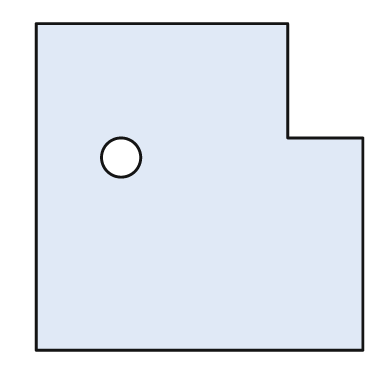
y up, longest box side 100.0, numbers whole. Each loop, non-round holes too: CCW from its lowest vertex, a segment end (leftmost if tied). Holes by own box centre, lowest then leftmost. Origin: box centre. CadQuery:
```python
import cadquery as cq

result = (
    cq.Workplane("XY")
    .moveTo(-50.0, -50.0)
    .lineTo(50.0, -50.0)
    .lineTo(50.0, 15.0)
    .lineTo(27.0, 15.0)
    .lineTo(27.0, 50.0)
    .lineTo(-50.0, 50.0)
    .close()
    .moveTo(-24.0, 9.0)
    .circle(6.0)
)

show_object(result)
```